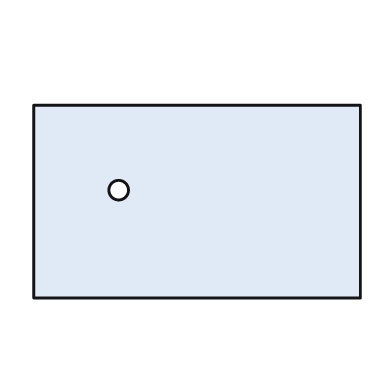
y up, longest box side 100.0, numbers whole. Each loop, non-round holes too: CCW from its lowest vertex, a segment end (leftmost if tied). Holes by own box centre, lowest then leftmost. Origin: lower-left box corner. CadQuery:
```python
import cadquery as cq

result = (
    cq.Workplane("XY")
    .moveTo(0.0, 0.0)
    .lineTo(100.0, 0.0)
    .lineTo(100.0, 59.0)
    .lineTo(0.0, 59.0)
    .close()
    .moveTo(26.0, 33.0)
    .circle(3.0)
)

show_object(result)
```